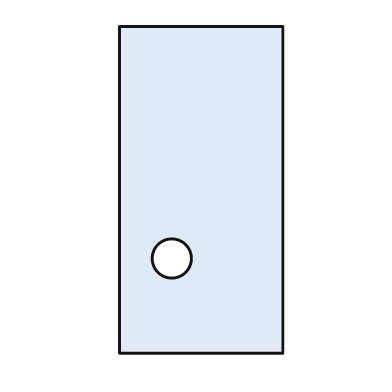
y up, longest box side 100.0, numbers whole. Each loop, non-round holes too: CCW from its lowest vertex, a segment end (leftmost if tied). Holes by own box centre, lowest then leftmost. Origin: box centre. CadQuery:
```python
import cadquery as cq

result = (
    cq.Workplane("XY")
    .moveTo(-25.0, -50.0)
    .lineTo(25.0, -50.0)
    .lineTo(25.0, 50.0)
    .lineTo(-25.0, 50.0)
    .close()
    .moveTo(-9.0, -21.0)
    .circle(6.0)
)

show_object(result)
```